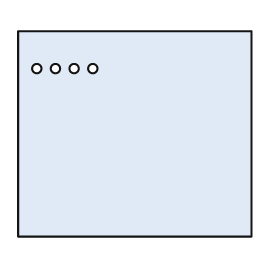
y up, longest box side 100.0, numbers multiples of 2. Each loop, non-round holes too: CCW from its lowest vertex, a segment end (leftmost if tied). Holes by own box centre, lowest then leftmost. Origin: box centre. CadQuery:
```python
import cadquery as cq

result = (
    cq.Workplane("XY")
    .moveTo(-50.0, -44.0)
    .lineTo(50.0, -44.0)
    .lineTo(50.0, 44.0)
    .lineTo(-50.0, 44.0)
    .close()
    .moveTo(-42.0, 28.0)
    .circle(2.0)
    .moveTo(-34.0, 28.0)
    .circle(2.0)
    .moveTo(-26.0, 28.0)
    .circle(2.0)
    .moveTo(-18.0, 28.0)
    .circle(2.0)
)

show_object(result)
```